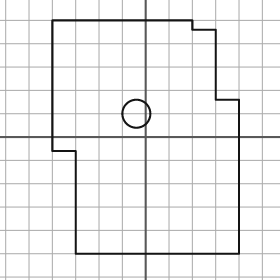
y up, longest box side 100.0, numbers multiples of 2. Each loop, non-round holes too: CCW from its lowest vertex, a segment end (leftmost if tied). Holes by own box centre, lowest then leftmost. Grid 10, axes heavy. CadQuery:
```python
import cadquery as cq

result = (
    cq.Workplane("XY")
    .moveTo(-30.0, -50.0)
    .lineTo(40.0, -50.0)
    .lineTo(40.0, 16.0)
    .lineTo(30.0, 16.0)
    .lineTo(30.0, 46.0)
    .lineTo(20.0, 46.0)
    .lineTo(20.0, 50.0)
    .lineTo(-40.0, 50.0)
    .lineTo(-40.0, -6.0)
    .lineTo(-30.0, -6.0)
    .close()
    .moveTo(-4.0, 10.0)
    .circle(6.0)
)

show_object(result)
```